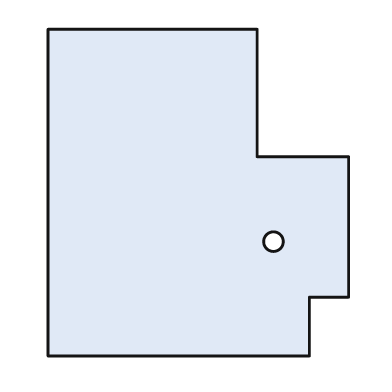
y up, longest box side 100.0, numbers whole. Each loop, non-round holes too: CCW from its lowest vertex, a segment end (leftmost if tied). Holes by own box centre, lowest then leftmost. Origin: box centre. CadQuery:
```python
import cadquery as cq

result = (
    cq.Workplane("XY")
    .moveTo(-46.0, -50.0)
    .lineTo(34.0, -50.0)
    .lineTo(34.0, -32.0)
    .lineTo(46.0, -32.0)
    .lineTo(46.0, 11.0)
    .lineTo(18.0, 11.0)
    .lineTo(18.0, 50.0)
    .lineTo(-46.0, 50.0)
    .close()
    .moveTo(23.0, -15.0)
    .circle(3.0)
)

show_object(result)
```